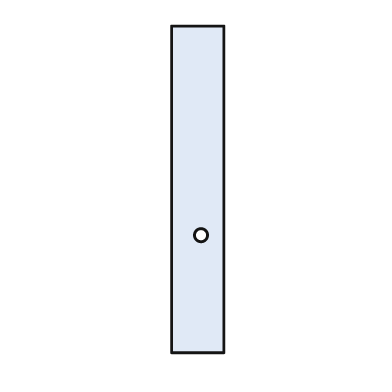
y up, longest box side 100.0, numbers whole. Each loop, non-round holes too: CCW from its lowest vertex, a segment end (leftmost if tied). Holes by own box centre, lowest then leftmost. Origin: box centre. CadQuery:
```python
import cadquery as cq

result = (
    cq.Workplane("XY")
    .moveTo(-8.0, -50.0)
    .lineTo(8.0, -50.0)
    .lineTo(8.0, 50.0)
    .lineTo(-8.0, 50.0)
    .close()
    .moveTo(1.0, -14.0)
    .circle(2.0)
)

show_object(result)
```